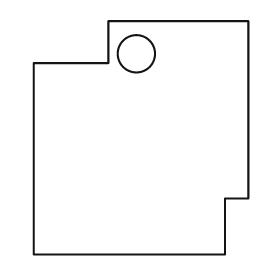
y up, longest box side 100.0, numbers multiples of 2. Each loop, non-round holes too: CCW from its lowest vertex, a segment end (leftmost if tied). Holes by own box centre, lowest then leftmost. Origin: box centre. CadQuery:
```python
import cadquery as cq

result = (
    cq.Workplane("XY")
    .moveTo(-46.0, -50.0)
    .lineTo(36.0, -50.0)
    .lineTo(36.0, -26.0)
    .lineTo(46.0, -26.0)
    .lineTo(46.0, 50.0)
    .lineTo(-14.0, 50.0)
    .lineTo(-14.0, 32.0)
    .lineTo(-46.0, 32.0)
    .close()
    .moveTo(-2.0, 36.0)
    .circle(8.0)
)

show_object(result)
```